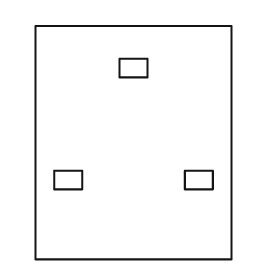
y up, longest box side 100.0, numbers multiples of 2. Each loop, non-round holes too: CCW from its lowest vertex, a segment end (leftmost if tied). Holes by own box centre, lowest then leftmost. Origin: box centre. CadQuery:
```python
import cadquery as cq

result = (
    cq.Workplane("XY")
    .moveTo(-42.0, -50.0)
    .lineTo(42.0, -50.0)
    .lineTo(42.0, 50.0)
    .lineTo(-42.0, 50.0)
    .close()
    .moveTo(-34.0, -20.0)
    .lineTo(-22.0, -20.0)
    .lineTo(-22.0, -12.0)
    .lineTo(-34.0, -12.0)
    .close()
    .moveTo(22.0, -20.0)
    .lineTo(34.0, -20.0)
    .lineTo(34.0, -12.0)
    .lineTo(22.0, -12.0)
    .close()
    .moveTo(-6.0, 28.0)
    .lineTo(6.0, 28.0)
    .lineTo(6.0, 36.0)
    .lineTo(-6.0, 36.0)
    .close()
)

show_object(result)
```